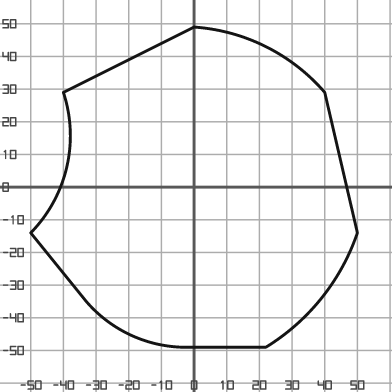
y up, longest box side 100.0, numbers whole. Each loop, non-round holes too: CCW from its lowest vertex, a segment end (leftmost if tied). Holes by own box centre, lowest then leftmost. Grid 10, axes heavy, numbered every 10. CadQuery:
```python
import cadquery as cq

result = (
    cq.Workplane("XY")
    .moveTo(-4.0, -49.0)
    .lineTo(22.0, -49.0)
    .threePointArc((39.0, -34.0), (50.0, -14.0))
    .lineTo(40.0, 29.0)
    .threePointArc((22.0, 43.0), (0.0, 49.0))
    .lineTo(-40.0, 29.0)
    .threePointArc((-39.0, 6.0), (-50.0, -14.0))
    .lineTo(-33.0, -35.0)
    .threePointArc((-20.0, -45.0), (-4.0, -49.0))
    .close()
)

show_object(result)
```